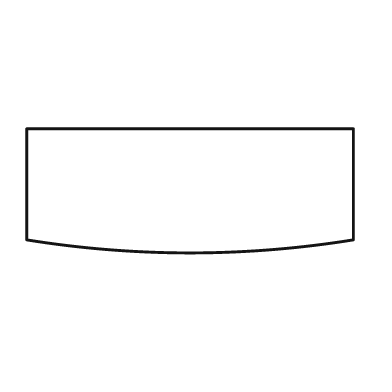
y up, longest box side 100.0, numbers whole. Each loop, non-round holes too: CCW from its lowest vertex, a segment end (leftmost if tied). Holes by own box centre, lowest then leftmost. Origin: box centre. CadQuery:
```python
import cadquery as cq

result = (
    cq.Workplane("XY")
    .moveTo(-50.0, -15.0)
    .threePointArc((0.0, -19.0), (50.0, -15.0))
    .lineTo(50.0, 19.0)
    .lineTo(-50.0, 19.0)
    .close()
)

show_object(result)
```